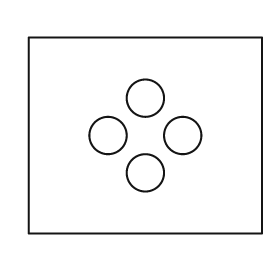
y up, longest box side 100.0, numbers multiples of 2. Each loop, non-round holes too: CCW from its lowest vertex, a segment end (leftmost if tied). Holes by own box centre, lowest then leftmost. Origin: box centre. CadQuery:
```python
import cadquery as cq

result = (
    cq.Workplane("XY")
    .moveTo(-50.0, -42.0)
    .lineTo(50.0, -42.0)
    .lineTo(50.0, 42.0)
    .lineTo(-50.0, 42.0)
    .close()
    .moveTo(0.0, -16.0)
    .circle(8.0)
    .moveTo(-16.0, 0.0)
    .circle(8.0)
    .moveTo(16.0, 0.0)
    .circle(8.0)
    .moveTo(0.0, 16.0)
    .circle(8.0)
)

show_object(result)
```